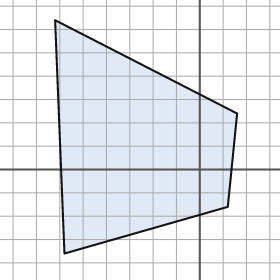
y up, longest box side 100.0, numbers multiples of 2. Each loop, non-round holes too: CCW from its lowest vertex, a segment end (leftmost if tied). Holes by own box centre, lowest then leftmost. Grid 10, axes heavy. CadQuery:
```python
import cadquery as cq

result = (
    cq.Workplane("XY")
    .moveTo(-58.0, -36.0)
    .lineTo(12.0, -16.0)
    .lineTo(16.0, 24.0)
    .lineTo(-62.0, 64.0)
    .close()
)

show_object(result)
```